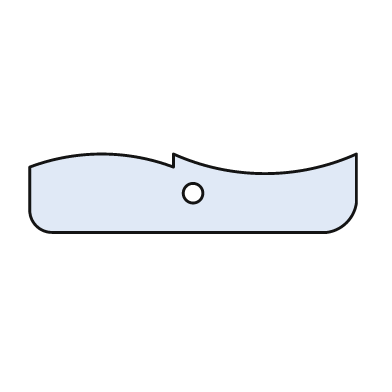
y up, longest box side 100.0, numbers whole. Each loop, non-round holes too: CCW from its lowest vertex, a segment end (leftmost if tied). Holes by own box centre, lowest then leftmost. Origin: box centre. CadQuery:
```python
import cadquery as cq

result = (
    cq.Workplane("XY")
    .moveTo(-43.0, -12.0)
    .lineTo(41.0, -12.0)
    .threePointArc((47.0, -9.0), (50.0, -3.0))
    .lineTo(50.0, 12.0)
    .threePointArc((22.0, 6.0), (-6.0, 12.0))
    .lineTo(-6.0, 8.0)
    .threePointArc((-28.0, 12.0), (-50.0, 8.0))
    .lineTo(-50.0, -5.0)
    .threePointArc((-48.0, -10.0), (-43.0, -12.0))
    .close()
    .moveTo(0.0, 0.0)
    .circle(3.0)
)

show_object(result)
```